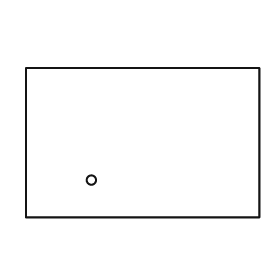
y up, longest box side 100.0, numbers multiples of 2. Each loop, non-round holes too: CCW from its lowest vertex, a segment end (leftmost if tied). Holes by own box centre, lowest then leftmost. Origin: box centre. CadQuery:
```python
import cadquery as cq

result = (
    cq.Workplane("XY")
    .moveTo(-50.0, -32.0)
    .lineTo(50.0, -32.0)
    .lineTo(50.0, 32.0)
    .lineTo(-50.0, 32.0)
    .close()
    .moveTo(-22.0, -16.0)
    .circle(2.0)
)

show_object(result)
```